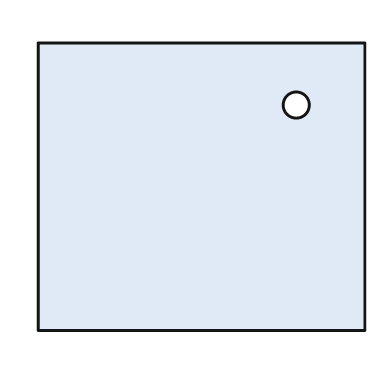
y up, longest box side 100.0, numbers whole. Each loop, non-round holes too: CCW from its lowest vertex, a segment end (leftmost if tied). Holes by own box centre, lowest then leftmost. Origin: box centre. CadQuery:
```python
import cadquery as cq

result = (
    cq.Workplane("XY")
    .moveTo(-50.0, -44.0)
    .lineTo(50.0, -44.0)
    .lineTo(50.0, 44.0)
    .lineTo(-50.0, 44.0)
    .close()
    .moveTo(29.0, 25.0)
    .circle(4.0)
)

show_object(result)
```